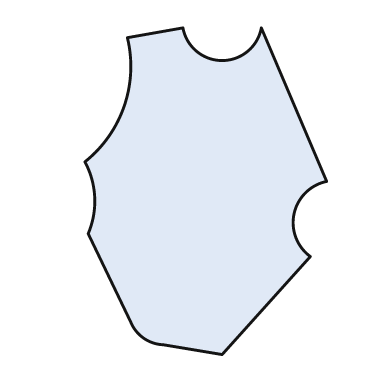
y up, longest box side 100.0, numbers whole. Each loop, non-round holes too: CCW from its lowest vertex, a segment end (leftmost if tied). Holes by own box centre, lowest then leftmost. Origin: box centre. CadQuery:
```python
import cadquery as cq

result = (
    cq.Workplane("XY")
    .moveTo(5.0, -50.0)
    .lineTo(32.0, -20.0)
    .threePointArc((27.0, -7.0), (37.0, 3.0))
    .lineTo(17.0, 50.0)
    .threePointArc((5.0, 40.0), (-7.0, 50.0))
    .lineTo(-24.0, 47.0)
    .threePointArc((-25.0, 26.0), (-37.0, 9.0))
    .threePointArc((-34.0, -2.0), (-36.0, -13.0))
    .lineTo(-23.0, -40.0)
    .threePointArc((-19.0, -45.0), (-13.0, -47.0))
    .close()
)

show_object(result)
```